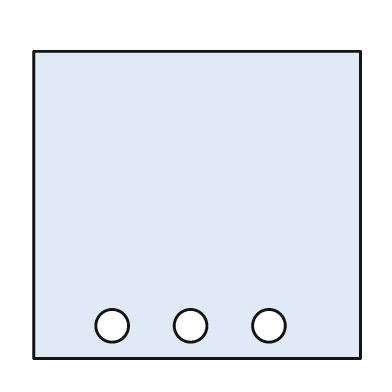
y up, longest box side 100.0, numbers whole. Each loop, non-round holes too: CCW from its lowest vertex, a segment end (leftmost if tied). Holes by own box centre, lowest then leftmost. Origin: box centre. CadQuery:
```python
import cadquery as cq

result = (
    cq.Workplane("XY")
    .moveTo(-50.0, -47.0)
    .lineTo(50.0, -47.0)
    .lineTo(50.0, 47.0)
    .lineTo(-50.0, 47.0)
    .close()
    .moveTo(-26.0, -37.0)
    .circle(5.0)
    .moveTo(-2.0, -37.0)
    .circle(5.0)
    .moveTo(22.0, -37.0)
    .circle(5.0)
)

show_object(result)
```